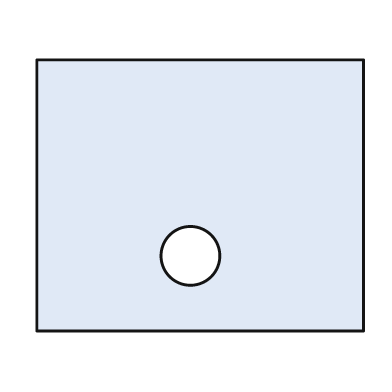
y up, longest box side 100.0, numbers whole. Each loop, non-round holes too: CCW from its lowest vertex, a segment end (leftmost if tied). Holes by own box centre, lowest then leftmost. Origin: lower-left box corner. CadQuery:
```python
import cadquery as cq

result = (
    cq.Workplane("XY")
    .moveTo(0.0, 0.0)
    .lineTo(100.0, 0.0)
    .lineTo(100.0, 83.0)
    .lineTo(0.0, 83.0)
    .close()
    .moveTo(47.0, 23.0)
    .circle(9.0)
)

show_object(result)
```